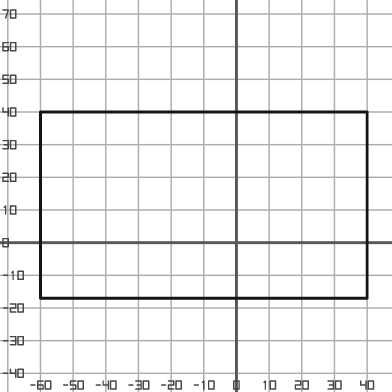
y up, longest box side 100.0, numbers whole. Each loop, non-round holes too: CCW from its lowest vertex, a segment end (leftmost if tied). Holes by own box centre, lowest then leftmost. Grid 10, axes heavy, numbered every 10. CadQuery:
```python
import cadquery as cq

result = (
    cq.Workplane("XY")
    .moveTo(-60.0, -17.0)
    .lineTo(40.0, -17.0)
    .lineTo(40.0, 40.0)
    .lineTo(-60.0, 40.0)
    .close()
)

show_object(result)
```